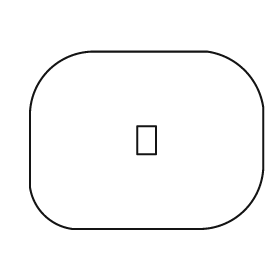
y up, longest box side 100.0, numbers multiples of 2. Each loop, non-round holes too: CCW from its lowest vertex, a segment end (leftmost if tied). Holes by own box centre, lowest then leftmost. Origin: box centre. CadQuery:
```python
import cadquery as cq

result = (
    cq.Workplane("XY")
    .moveTo(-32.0, -38.0)
    .lineTo(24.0, -38.0)
    .threePointArc((42.0, -30.0), (50.0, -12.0))
    .lineTo(50.0, 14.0)
    .threePointArc((42.0, 30.0), (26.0, 38.0))
    .lineTo(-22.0, 38.0)
    .threePointArc((-42.0, 30.0), (-50.0, 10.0))
    .lineTo(-50.0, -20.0)
    .threePointArc((-44.0, -32.0), (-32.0, -38.0))
    .close()
    .moveTo(-4.0, -6.0)
    .lineTo(4.0, -6.0)
    .lineTo(4.0, 6.0)
    .lineTo(-4.0, 6.0)
    .close()
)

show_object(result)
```